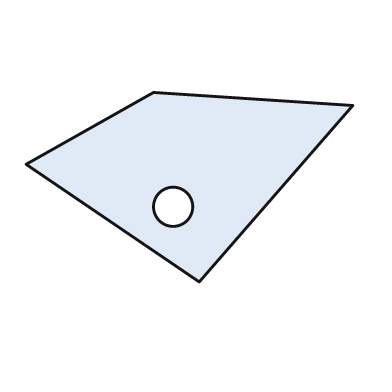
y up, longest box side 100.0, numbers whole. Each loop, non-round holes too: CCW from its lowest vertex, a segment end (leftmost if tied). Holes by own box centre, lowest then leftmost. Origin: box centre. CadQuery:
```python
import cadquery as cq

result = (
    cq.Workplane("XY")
    .moveTo(3.0, -29.0)
    .lineTo(50.0, 25.0)
    .lineTo(-11.0, 29.0)
    .lineTo(-50.0, 7.0)
    .close()
    .moveTo(-5.0, -6.0)
    .circle(6.0)
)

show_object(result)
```